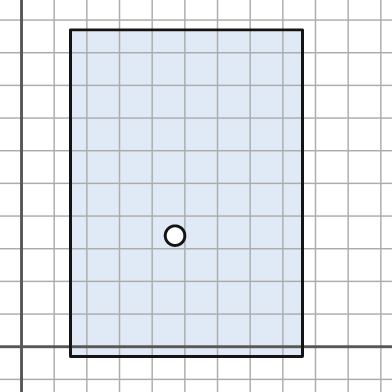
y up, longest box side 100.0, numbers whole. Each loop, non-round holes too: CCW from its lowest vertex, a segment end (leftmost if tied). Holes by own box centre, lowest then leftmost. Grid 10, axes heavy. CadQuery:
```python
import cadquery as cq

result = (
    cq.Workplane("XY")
    .moveTo(15.0, -3.0)
    .lineTo(86.0, -3.0)
    .lineTo(86.0, 97.0)
    .lineTo(15.0, 97.0)
    .close()
    .moveTo(47.0, 34.0)
    .circle(3.0)
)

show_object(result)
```